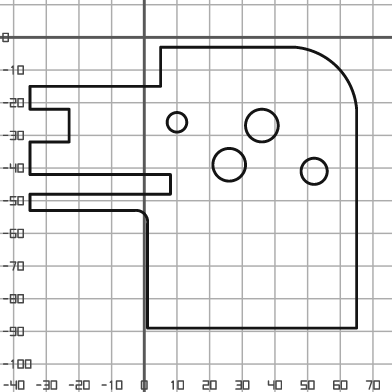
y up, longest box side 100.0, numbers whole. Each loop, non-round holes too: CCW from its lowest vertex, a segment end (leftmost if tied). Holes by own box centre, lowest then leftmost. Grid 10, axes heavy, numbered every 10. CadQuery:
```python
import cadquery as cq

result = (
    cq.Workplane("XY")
    .moveTo(1.0, -89.0)
    .lineTo(65.0, -89.0)
    .lineTo(65.0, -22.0)
    .threePointArc((59.0, -9.0), (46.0, -3.0))
    .lineTo(5.0, -3.0)
    .lineTo(5.0, -15.0)
    .lineTo(-35.0, -15.0)
    .lineTo(-35.0, -22.0)
    .lineTo(-23.0, -22.0)
    .lineTo(-23.0, -32.0)
    .lineTo(-35.0, -32.0)
    .lineTo(-35.0, -42.0)
    .lineTo(8.0, -42.0)
    .lineTo(8.0, -48.0)
    .lineTo(-35.0, -48.0)
    .lineTo(-35.0, -53.0)
    .lineTo(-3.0, -53.0)
    .threePointArc((0.0, -54.0), (1.0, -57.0))
    .close()
    .moveTo(52.0, -41.0)
    .circle(4.0)
    .moveTo(26.0, -39.0)
    .circle(5.0)
    .moveTo(36.0, -27.0)
    .circle(5.0)
    .moveTo(10.0, -26.0)
    .circle(3.0)
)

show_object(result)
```